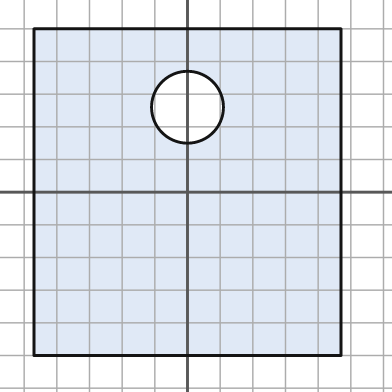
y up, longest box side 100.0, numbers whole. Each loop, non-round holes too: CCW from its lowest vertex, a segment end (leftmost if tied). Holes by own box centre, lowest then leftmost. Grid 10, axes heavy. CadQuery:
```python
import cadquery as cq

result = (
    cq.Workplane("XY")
    .moveTo(-47.0, -50.0)
    .lineTo(47.0, -50.0)
    .lineTo(47.0, 50.0)
    .lineTo(-47.0, 50.0)
    .close()
    .moveTo(0.0, 26.0)
    .circle(11.0)
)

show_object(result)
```